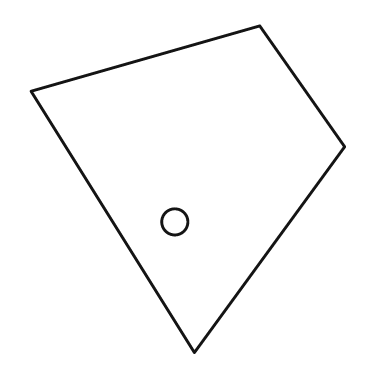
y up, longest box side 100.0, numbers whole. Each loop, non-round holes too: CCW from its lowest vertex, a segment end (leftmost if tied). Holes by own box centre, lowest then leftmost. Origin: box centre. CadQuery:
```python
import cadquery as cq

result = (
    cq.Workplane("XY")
    .moveTo(2.0, -50.0)
    .lineTo(48.0, 13.0)
    .lineTo(22.0, 50.0)
    .lineTo(-48.0, 30.0)
    .close()
    .moveTo(-4.0, -10.0)
    .circle(4.0)
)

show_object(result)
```